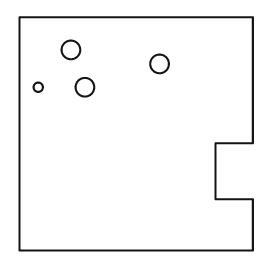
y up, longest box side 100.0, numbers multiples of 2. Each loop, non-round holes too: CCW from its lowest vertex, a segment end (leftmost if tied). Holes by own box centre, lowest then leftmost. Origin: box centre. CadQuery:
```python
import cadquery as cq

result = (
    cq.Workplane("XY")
    .moveTo(-50.0, -50.0)
    .lineTo(50.0, -50.0)
    .lineTo(50.0, -28.0)
    .lineTo(34.0, -28.0)
    .lineTo(34.0, -4.0)
    .lineTo(50.0, -4.0)
    .lineTo(50.0, 50.0)
    .lineTo(-50.0, 50.0)
    .close()
    .moveTo(-42.0, 20.0)
    .circle(2.0)
    .moveTo(-22.0, 20.0)
    .circle(4.0)
    .moveTo(10.0, 30.0)
    .circle(4.0)
    .moveTo(-28.0, 36.0)
    .circle(4.0)
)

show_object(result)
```